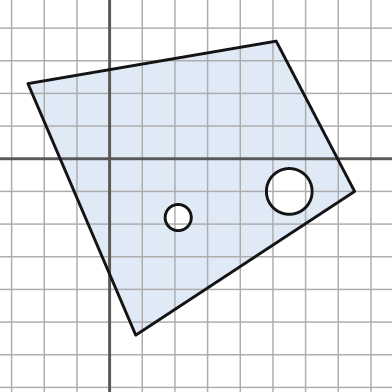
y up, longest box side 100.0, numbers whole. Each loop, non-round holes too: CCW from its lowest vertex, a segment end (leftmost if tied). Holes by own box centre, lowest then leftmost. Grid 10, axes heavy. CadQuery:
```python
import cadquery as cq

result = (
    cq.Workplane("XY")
    .moveTo(8.0, -54.0)
    .lineTo(75.0, -10.0)
    .lineTo(51.0, 36.0)
    .lineTo(-25.0, 23.0)
    .close()
    .moveTo(21.0, -18.0)
    .circle(4.0)
    .moveTo(55.0, -10.0)
    .circle(7.0)
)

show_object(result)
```